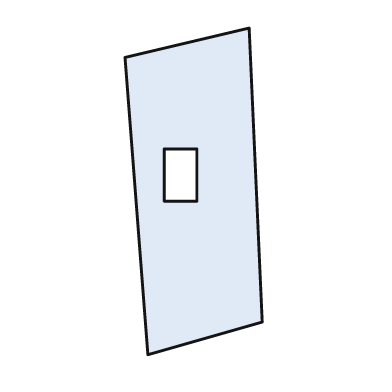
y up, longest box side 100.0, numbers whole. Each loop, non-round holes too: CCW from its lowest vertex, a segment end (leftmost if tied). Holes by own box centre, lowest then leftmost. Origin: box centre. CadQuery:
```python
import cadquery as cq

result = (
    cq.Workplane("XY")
    .moveTo(-14.0, -50.0)
    .lineTo(21.0, -40.0)
    .lineTo(17.0, 50.0)
    .lineTo(-21.0, 41.0)
    .close()
    .moveTo(-9.0, -3.0)
    .lineTo(1.0, -3.0)
    .lineTo(1.0, 13.0)
    .lineTo(-9.0, 13.0)
    .close()
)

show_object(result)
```